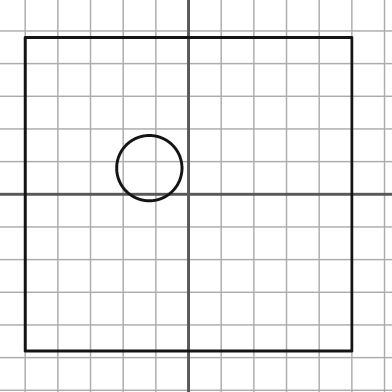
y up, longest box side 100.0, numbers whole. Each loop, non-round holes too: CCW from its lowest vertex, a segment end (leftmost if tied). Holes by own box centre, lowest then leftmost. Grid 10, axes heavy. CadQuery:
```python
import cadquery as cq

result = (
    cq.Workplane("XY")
    .moveTo(-50.0, -48.0)
    .lineTo(50.0, -48.0)
    .lineTo(50.0, 48.0)
    .lineTo(-50.0, 48.0)
    .close()
    .moveTo(-12.0, 8.0)
    .circle(10.0)
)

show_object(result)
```